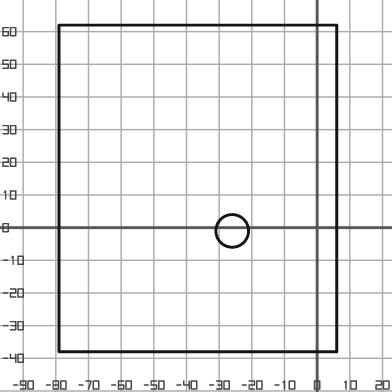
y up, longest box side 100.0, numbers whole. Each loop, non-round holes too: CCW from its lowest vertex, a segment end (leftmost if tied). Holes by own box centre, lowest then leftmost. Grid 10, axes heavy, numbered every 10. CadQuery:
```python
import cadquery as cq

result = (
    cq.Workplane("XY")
    .moveTo(-79.0, -38.0)
    .lineTo(6.0, -38.0)
    .lineTo(6.0, 62.0)
    .lineTo(-79.0, 62.0)
    .close()
    .moveTo(-26.0, -1.0)
    .circle(5.0)
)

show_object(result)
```